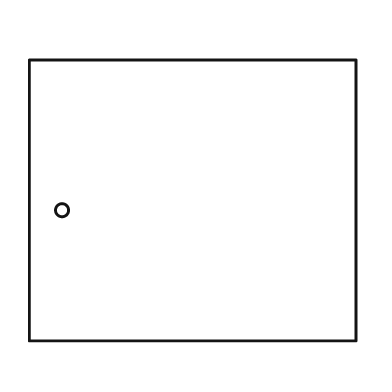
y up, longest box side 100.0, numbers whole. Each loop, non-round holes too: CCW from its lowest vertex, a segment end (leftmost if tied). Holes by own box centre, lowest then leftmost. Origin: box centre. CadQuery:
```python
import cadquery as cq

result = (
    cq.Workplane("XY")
    .moveTo(-50.0, -43.0)
    .lineTo(50.0, -43.0)
    .lineTo(50.0, 43.0)
    .lineTo(-50.0, 43.0)
    .close()
    .moveTo(-40.0, -3.0)
    .circle(2.0)
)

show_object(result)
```